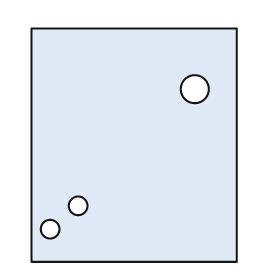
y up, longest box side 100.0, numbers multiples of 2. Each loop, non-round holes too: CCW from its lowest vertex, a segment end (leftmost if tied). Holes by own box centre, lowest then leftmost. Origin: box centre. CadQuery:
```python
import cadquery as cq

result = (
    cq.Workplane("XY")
    .moveTo(-44.0, -50.0)
    .lineTo(44.0, -50.0)
    .lineTo(44.0, 50.0)
    .lineTo(-44.0, 50.0)
    .close()
    .moveTo(-36.0, -36.0)
    .circle(4.0)
    .moveTo(-24.0, -26.0)
    .circle(4.0)
    .moveTo(26.0, 24.0)
    .circle(6.0)
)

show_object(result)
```